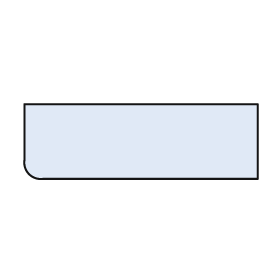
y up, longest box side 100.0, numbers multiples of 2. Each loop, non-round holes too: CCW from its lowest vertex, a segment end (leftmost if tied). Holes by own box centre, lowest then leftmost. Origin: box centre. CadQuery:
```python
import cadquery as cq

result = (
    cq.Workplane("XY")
    .moveTo(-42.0, -16.0)
    .lineTo(50.0, -16.0)
    .lineTo(50.0, 16.0)
    .lineTo(-50.0, 16.0)
    .lineTo(-50.0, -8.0)
    .threePointArc((-48.0, -14.0), (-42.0, -16.0))
    .close()
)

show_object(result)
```